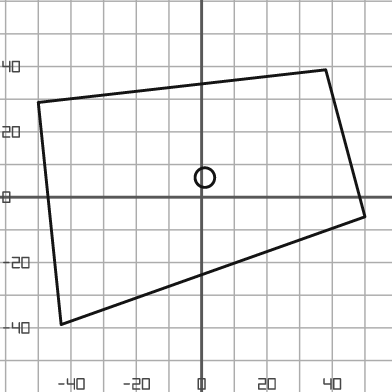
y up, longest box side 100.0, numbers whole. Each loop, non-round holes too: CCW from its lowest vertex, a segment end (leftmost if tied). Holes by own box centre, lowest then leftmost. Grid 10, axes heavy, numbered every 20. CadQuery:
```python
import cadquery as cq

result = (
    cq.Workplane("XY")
    .moveTo(-43.0, -39.0)
    .lineTo(50.0, -6.0)
    .lineTo(38.0, 39.0)
    .lineTo(-50.0, 29.0)
    .close()
    .moveTo(1.0, 6.0)
    .circle(3.0)
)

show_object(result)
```